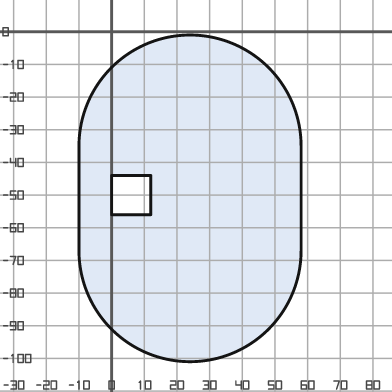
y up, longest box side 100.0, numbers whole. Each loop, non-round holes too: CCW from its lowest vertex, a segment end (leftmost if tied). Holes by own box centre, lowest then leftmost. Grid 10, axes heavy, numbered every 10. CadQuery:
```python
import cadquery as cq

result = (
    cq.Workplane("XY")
    .moveTo(-10.0, -67.0)
    .threePointArc((24.0, -101.0), (58.0, -67.0))
    .lineTo(58.0, -35.0)
    .threePointArc((24.0, -1.0), (-10.0, -35.0))
    .close()
    .moveTo(0.0, -56.0)
    .lineTo(12.0, -56.0)
    .lineTo(12.0, -44.0)
    .lineTo(0.0, -44.0)
    .close()
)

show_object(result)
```